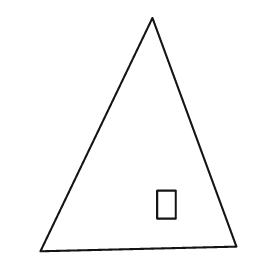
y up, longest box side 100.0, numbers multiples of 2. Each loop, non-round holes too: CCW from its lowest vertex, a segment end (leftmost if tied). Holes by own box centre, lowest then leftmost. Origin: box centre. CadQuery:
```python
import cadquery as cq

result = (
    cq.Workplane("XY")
    .moveTo(-42.0, -50.0)
    .lineTo(42.0, -48.0)
    .lineTo(6.0, 50.0)
    .close()
    .moveTo(8.0, -36.0)
    .lineTo(16.0, -36.0)
    .lineTo(16.0, -24.0)
    .lineTo(8.0, -24.0)
    .close()
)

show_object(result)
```